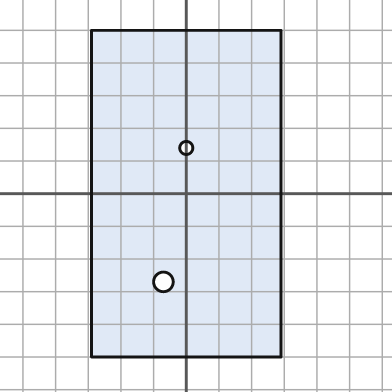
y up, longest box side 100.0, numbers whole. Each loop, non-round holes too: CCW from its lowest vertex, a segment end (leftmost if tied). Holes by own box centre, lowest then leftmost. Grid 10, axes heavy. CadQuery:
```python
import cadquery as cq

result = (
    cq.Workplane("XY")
    .moveTo(-29.0, -50.0)
    .lineTo(29.0, -50.0)
    .lineTo(29.0, 50.0)
    .lineTo(-29.0, 50.0)
    .close()
    .moveTo(-7.0, -27.0)
    .circle(3.0)
    .moveTo(0.0, 14.0)
    .circle(2.0)
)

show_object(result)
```